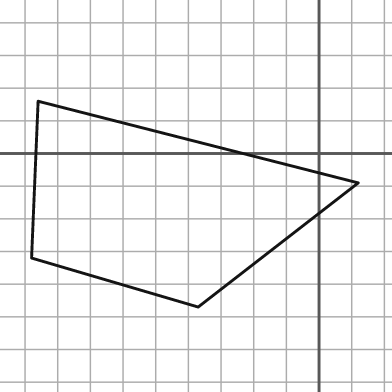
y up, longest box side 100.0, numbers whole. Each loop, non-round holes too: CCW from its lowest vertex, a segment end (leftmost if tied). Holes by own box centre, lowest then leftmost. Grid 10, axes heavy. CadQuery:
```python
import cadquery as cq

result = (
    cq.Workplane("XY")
    .moveTo(-37.0, -47.0)
    .lineTo(12.0, -9.0)
    .lineTo(-86.0, 16.0)
    .lineTo(-88.0, -32.0)
    .close()
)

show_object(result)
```